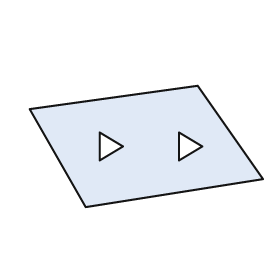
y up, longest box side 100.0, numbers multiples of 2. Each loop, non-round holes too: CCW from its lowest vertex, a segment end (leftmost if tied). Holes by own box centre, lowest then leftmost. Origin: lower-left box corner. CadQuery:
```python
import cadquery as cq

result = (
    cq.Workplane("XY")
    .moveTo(24.0, 0.0)
    .lineTo(100.0, 12.0)
    .lineTo(72.0, 52.0)
    .lineTo(0.0, 42.0)
    .close()
    .moveTo(30.0, 20.0)
    .lineTo(40.0, 26.0)
    .lineTo(30.0, 32.0)
    .close()
    .moveTo(64.0, 20.0)
    .lineTo(74.0, 26.0)
    .lineTo(64.0, 32.0)
    .close()
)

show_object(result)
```